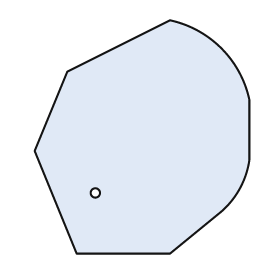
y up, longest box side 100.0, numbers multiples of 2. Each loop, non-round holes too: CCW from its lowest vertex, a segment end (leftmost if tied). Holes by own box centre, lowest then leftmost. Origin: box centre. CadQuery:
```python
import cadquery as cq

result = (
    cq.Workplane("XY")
    .moveTo(-28.0, -50.0)
    .lineTo(12.0, -50.0)
    .lineTo(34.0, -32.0)
    .threePointArc((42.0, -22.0), (46.0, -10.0))
    .lineTo(46.0, 16.0)
    .threePointArc((34.0, 38.0), (12.0, 50.0))
    .lineTo(-32.0, 28.0)
    .lineTo(-46.0, -6.0)
    .close()
    .moveTo(-20.0, -24.0)
    .circle(2.0)
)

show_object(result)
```